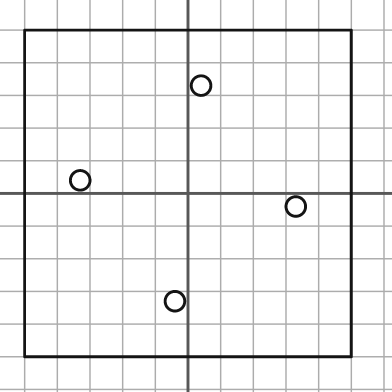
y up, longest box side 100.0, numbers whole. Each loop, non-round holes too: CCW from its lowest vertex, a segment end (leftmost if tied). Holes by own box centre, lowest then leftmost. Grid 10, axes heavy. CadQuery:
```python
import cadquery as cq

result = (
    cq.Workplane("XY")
    .moveTo(-50.0, -50.0)
    .lineTo(50.0, -50.0)
    .lineTo(50.0, 50.0)
    .lineTo(-50.0, 50.0)
    .close()
    .moveTo(-4.0, -33.0)
    .circle(3.0)
    .moveTo(33.0, -4.0)
    .circle(3.0)
    .moveTo(-33.0, 4.0)
    .circle(3.0)
    .moveTo(4.0, 33.0)
    .circle(3.0)
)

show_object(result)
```